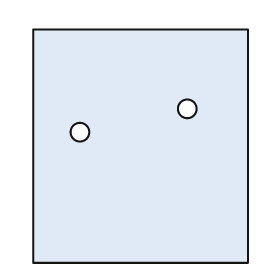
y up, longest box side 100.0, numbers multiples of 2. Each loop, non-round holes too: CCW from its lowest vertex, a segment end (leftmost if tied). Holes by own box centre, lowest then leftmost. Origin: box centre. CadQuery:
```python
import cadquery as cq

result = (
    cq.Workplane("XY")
    .moveTo(-46.0, -50.0)
    .lineTo(46.0, -50.0)
    .lineTo(46.0, 50.0)
    .lineTo(-46.0, 50.0)
    .close()
    .moveTo(-26.0, 6.0)
    .circle(4.0)
    .moveTo(20.0, 16.0)
    .circle(4.0)
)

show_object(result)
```